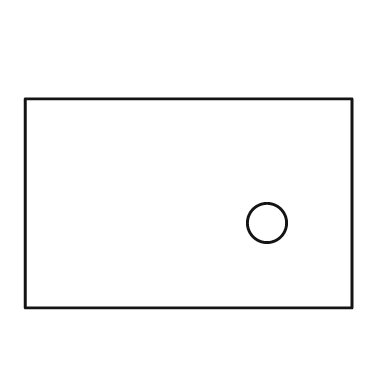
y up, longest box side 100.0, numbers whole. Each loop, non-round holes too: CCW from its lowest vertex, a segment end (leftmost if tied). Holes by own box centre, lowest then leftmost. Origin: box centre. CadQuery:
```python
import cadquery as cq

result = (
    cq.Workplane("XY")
    .moveTo(-50.0, -32.0)
    .lineTo(50.0, -32.0)
    .lineTo(50.0, 32.0)
    .lineTo(-50.0, 32.0)
    .close()
    .moveTo(24.0, -6.0)
    .circle(6.0)
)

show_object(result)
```